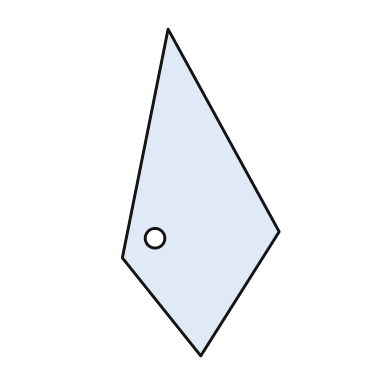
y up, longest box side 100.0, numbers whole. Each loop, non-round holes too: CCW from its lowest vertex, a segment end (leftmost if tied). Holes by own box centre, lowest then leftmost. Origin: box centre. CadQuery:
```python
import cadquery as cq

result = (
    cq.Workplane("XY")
    .moveTo(0.0, -50.0)
    .lineTo(24.0, -12.0)
    .lineTo(-10.0, 50.0)
    .lineTo(-24.0, -20.0)
    .close()
    .moveTo(-14.0, -14.0)
    .circle(3.0)
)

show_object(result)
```